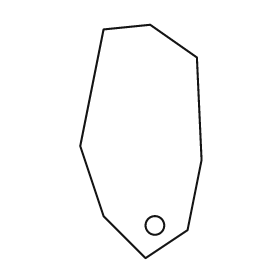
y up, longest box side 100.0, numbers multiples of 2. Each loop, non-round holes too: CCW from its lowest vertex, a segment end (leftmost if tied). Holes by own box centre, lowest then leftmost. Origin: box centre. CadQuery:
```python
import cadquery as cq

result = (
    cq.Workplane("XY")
    .moveTo(2.0, -50.0)
    .lineTo(20.0, -38.0)
    .lineTo(26.0, -8.0)
    .lineTo(24.0, 36.0)
    .lineTo(4.0, 50.0)
    .lineTo(-16.0, 48.0)
    .lineTo(-26.0, -2.0)
    .lineTo(-16.0, -32.0)
    .close()
    .moveTo(6.0, -36.0)
    .circle(4.0)
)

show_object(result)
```